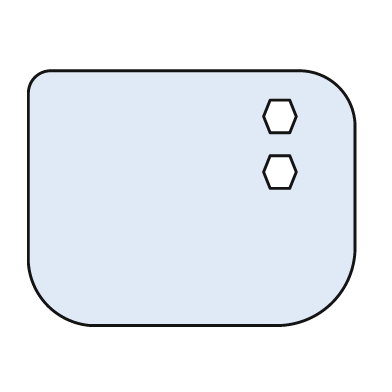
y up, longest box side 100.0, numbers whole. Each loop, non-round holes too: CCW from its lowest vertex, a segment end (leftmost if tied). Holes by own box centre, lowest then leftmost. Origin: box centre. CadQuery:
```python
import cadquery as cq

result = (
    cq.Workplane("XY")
    .moveTo(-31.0, -39.0)
    .lineTo(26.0, -39.0)
    .threePointArc((43.0, -32.0), (50.0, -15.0))
    .lineTo(50.0, 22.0)
    .threePointArc((45.0, 34.0), (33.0, 39.0))
    .lineTo(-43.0, 39.0)
    .threePointArc((-48.0, 37.0), (-50.0, 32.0))
    .lineTo(-50.0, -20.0)
    .threePointArc((-44.0, -33.0), (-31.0, -39.0))
    .close()
    .moveTo(24.0, 3.0)
    .lineTo(30.0, 3.0)
    .lineTo(32.0, 8.0)
    .lineTo(30.0, 13.0)
    .lineTo(24.0, 13.0)
    .lineTo(22.0, 8.0)
    .close()
    .moveTo(24.0, 20.0)
    .lineTo(30.0, 20.0)
    .lineTo(32.0, 25.0)
    .lineTo(30.0, 30.0)
    .lineTo(24.0, 30.0)
    .lineTo(22.0, 25.0)
    .close()
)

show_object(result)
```